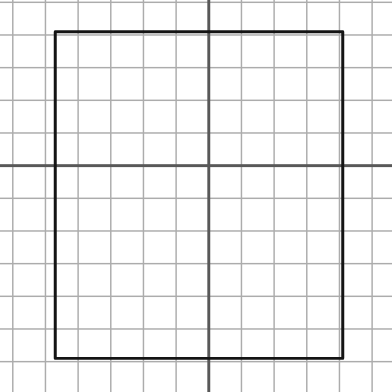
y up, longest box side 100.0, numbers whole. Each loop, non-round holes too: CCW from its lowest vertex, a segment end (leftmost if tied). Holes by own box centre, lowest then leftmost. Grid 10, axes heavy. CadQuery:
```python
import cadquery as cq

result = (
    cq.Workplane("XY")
    .moveTo(-47.0, -59.0)
    .lineTo(41.0, -59.0)
    .lineTo(41.0, 41.0)
    .lineTo(-47.0, 41.0)
    .close()
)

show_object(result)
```